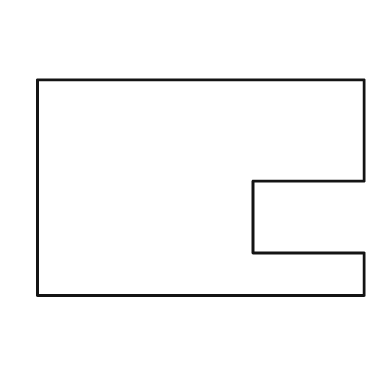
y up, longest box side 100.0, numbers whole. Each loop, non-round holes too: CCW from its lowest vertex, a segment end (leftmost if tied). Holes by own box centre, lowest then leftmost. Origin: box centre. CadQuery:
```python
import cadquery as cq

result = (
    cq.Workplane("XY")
    .moveTo(-50.0, -33.0)
    .lineTo(50.0, -33.0)
    .lineTo(50.0, -20.0)
    .lineTo(16.0, -20.0)
    .lineTo(16.0, 2.0)
    .lineTo(50.0, 2.0)
    .lineTo(50.0, 33.0)
    .lineTo(-50.0, 33.0)
    .close()
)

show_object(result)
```